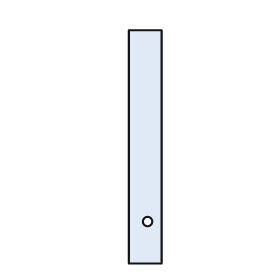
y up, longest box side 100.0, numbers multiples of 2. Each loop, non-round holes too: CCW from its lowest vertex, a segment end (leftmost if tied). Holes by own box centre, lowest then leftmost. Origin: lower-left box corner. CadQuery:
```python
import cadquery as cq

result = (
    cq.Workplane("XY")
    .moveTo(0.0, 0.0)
    .lineTo(14.0, 0.0)
    .lineTo(14.0, 100.0)
    .lineTo(0.0, 100.0)
    .close()
    .moveTo(8.0, 18.0)
    .circle(2.0)
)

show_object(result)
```